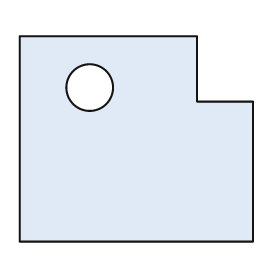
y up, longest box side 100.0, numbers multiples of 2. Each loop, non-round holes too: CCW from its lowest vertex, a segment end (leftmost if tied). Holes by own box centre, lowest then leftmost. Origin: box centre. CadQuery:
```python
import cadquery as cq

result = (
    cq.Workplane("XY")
    .moveTo(-50.0, -44.0)
    .lineTo(50.0, -44.0)
    .lineTo(50.0, 16.0)
    .lineTo(26.0, 16.0)
    .lineTo(26.0, 44.0)
    .lineTo(-50.0, 44.0)
    .close()
    .moveTo(-20.0, 22.0)
    .circle(10.0)
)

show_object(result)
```